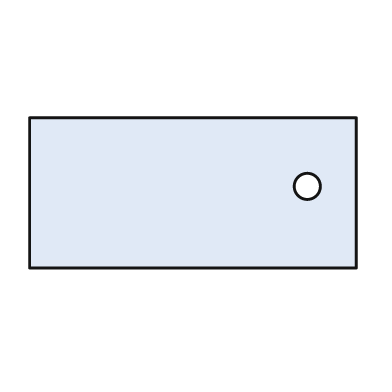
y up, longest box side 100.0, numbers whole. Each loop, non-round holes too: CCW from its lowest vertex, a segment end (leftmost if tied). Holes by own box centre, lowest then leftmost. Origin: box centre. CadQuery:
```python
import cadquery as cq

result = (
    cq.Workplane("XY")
    .moveTo(-50.0, -23.0)
    .lineTo(50.0, -23.0)
    .lineTo(50.0, 23.0)
    .lineTo(-50.0, 23.0)
    .close()
    .moveTo(35.0, 2.0)
    .circle(4.0)
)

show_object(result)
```